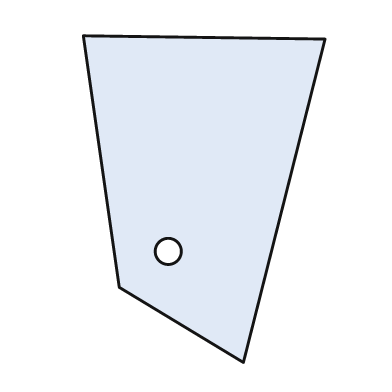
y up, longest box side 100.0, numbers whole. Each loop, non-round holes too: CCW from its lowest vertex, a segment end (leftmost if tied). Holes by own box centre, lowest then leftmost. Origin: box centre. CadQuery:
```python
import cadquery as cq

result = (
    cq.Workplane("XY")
    .moveTo(12.0, -50.0)
    .lineTo(37.0, 49.0)
    .lineTo(-37.0, 50.0)
    .lineTo(-26.0, -27.0)
    .close()
    .moveTo(-11.0, -16.0)
    .circle(4.0)
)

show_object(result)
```